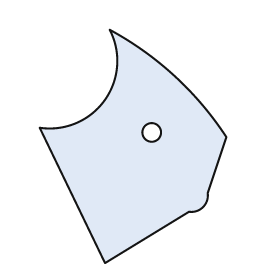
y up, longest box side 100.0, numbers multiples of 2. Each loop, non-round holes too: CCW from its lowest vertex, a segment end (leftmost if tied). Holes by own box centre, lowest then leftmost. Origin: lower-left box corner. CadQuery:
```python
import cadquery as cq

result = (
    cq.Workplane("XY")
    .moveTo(28.0, 0.0)
    .lineTo(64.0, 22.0)
    .threePointArc((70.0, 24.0), (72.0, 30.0))
    .lineTo(80.0, 54.0)
    .threePointArc((58.0, 80.0), (30.0, 100.0))
    .threePointArc((28.0, 70.0), (0.0, 58.0))
    .close()
    .moveTo(48.0, 56.0)
    .circle(4.0)
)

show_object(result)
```